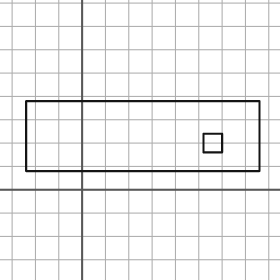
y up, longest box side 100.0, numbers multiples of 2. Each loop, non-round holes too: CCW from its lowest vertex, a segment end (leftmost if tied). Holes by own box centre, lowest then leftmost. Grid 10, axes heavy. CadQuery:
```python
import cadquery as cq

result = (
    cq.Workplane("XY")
    .moveTo(-24.0, 8.0)
    .lineTo(76.0, 8.0)
    .lineTo(76.0, 38.0)
    .lineTo(-24.0, 38.0)
    .close()
    .moveTo(52.0, 16.0)
    .lineTo(60.0, 16.0)
    .lineTo(60.0, 24.0)
    .lineTo(52.0, 24.0)
    .close()
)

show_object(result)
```